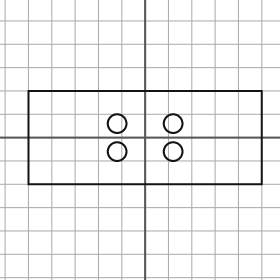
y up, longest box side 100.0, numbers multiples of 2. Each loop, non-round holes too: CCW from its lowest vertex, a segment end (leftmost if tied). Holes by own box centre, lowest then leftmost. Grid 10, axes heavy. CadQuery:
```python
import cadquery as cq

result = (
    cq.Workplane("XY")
    .moveTo(-50.0, -20.0)
    .lineTo(50.0, -20.0)
    .lineTo(50.0, 20.0)
    .lineTo(-50.0, 20.0)
    .close()
    .moveTo(-12.0, -6.0)
    .circle(4.0)
    .moveTo(12.0, -6.0)
    .circle(4.0)
    .moveTo(-12.0, 6.0)
    .circle(4.0)
    .moveTo(12.0, 6.0)
    .circle(4.0)
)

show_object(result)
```